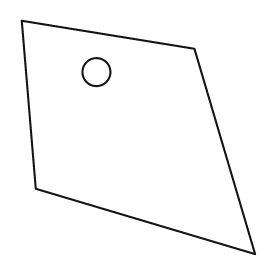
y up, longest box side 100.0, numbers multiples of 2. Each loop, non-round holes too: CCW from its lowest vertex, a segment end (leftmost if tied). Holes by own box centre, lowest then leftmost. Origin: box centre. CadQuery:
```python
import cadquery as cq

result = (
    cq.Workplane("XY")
    .moveTo(50.0, -50.0)
    .lineTo(24.0, 38.0)
    .lineTo(-50.0, 50.0)
    .lineTo(-44.0, -22.0)
    .close()
    .moveTo(-18.0, 28.0)
    .circle(6.0)
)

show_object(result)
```